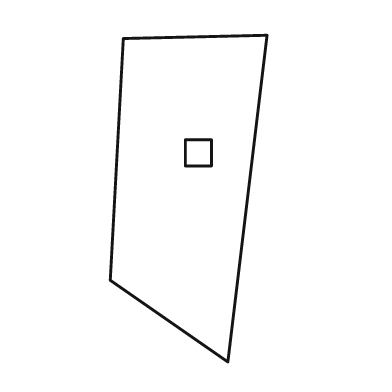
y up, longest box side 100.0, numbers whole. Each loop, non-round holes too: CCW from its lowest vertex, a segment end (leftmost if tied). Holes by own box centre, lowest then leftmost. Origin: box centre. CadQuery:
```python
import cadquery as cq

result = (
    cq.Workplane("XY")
    .moveTo(12.0, -50.0)
    .lineTo(24.0, 50.0)
    .lineTo(-20.0, 49.0)
    .lineTo(-24.0, -25.0)
    .close()
    .moveTo(-1.0, 10.0)
    .lineTo(7.0, 10.0)
    .lineTo(7.0, 18.0)
    .lineTo(-1.0, 18.0)
    .close()
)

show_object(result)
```